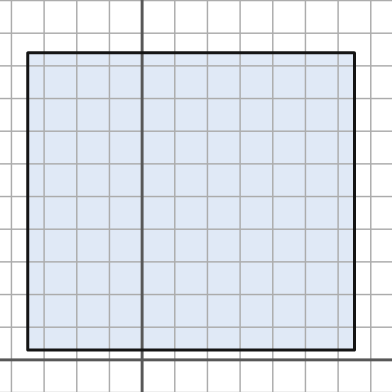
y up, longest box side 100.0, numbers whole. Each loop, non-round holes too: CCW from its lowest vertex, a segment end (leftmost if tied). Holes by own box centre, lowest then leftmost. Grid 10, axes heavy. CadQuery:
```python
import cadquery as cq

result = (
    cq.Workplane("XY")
    .moveTo(-35.0, 3.0)
    .lineTo(65.0, 3.0)
    .lineTo(65.0, 94.0)
    .lineTo(-35.0, 94.0)
    .close()
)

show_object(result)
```